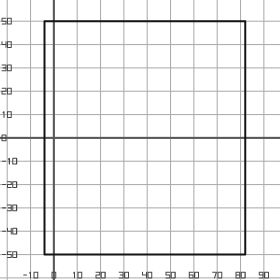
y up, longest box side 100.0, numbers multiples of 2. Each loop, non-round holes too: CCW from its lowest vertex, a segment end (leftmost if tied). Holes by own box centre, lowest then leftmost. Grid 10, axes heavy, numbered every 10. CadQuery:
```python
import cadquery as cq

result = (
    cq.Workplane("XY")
    .moveTo(-4.0, -50.0)
    .lineTo(82.0, -50.0)
    .lineTo(82.0, 50.0)
    .lineTo(-4.0, 50.0)
    .close()
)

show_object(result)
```